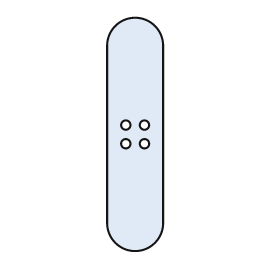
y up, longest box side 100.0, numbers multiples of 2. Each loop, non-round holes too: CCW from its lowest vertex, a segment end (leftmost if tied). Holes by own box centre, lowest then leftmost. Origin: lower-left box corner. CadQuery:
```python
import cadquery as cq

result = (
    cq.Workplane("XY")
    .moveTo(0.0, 12.0)
    .threePointArc((12.0, 0.0), (24.0, 12.0))
    .lineTo(24.0, 88.0)
    .threePointArc((12.0, 100.0), (0.0, 88.0))
    .close()
    .moveTo(8.0, 46.0)
    .circle(2.0)
    .moveTo(16.0, 46.0)
    .circle(2.0)
    .moveTo(8.0, 54.0)
    .circle(2.0)
    .moveTo(16.0, 54.0)
    .circle(2.0)
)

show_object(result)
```